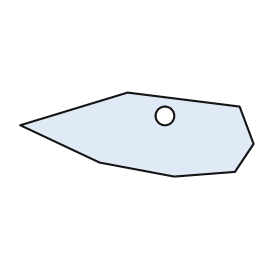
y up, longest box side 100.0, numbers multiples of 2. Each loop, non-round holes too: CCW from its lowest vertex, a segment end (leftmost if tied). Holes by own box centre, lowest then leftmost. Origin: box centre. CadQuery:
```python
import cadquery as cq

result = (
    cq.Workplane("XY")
    .moveTo(16.0, -18.0)
    .lineTo(42.0, -16.0)
    .lineTo(50.0, -4.0)
    .lineTo(44.0, 12.0)
    .lineTo(-4.0, 18.0)
    .lineTo(-50.0, 4.0)
    .lineTo(-16.0, -12.0)
    .close()
    .moveTo(12.0, 8.0)
    .circle(4.0)
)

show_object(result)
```